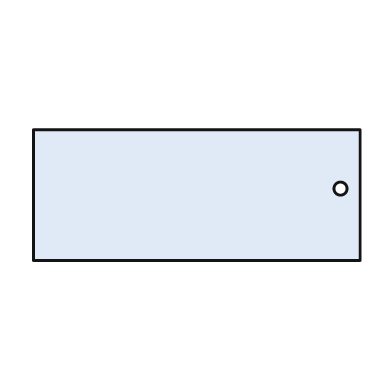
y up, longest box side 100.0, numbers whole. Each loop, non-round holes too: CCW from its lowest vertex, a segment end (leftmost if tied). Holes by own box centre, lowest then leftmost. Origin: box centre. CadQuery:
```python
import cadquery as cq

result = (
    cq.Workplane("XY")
    .moveTo(-50.0, -20.0)
    .lineTo(50.0, -20.0)
    .lineTo(50.0, 20.0)
    .lineTo(-50.0, 20.0)
    .close()
    .moveTo(44.0, 2.0)
    .circle(2.0)
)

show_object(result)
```